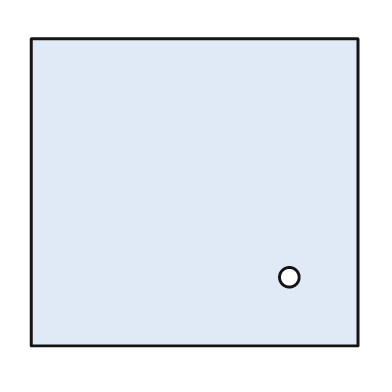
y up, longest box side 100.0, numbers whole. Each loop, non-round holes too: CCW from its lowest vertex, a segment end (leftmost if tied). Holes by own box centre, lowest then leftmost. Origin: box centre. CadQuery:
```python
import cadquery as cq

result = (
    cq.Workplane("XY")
    .moveTo(-50.0, -47.0)
    .lineTo(50.0, -47.0)
    .lineTo(50.0, 47.0)
    .lineTo(-50.0, 47.0)
    .close()
    .moveTo(29.0, -26.0)
    .circle(3.0)
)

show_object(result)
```